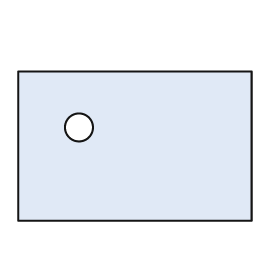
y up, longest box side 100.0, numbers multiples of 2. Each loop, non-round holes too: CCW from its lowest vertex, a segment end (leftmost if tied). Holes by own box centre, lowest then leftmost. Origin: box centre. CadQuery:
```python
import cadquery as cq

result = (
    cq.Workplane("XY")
    .moveTo(-50.0, -32.0)
    .lineTo(50.0, -32.0)
    .lineTo(50.0, 32.0)
    .lineTo(-50.0, 32.0)
    .close()
    .moveTo(-24.0, 8.0)
    .circle(6.0)
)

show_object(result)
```